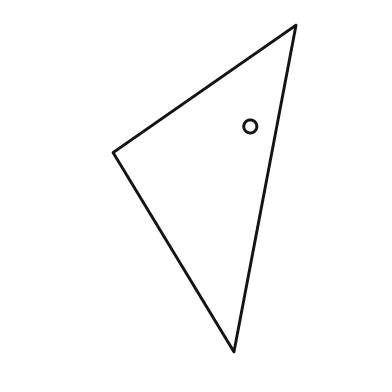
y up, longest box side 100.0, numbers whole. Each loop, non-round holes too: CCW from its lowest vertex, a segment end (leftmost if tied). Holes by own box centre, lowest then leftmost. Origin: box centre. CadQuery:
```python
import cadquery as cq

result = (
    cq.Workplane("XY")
    .moveTo(9.0, -50.0)
    .lineTo(28.0, 50.0)
    .lineTo(-28.0, 11.0)
    .close()
    .moveTo(14.0, 19.0)
    .circle(2.0)
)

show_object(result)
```